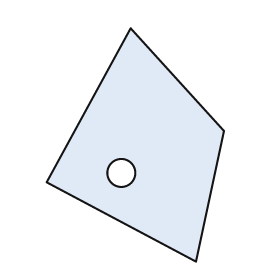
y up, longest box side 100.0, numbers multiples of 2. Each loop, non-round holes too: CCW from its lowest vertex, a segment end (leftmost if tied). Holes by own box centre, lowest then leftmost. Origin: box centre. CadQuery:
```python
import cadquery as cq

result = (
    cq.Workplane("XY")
    .moveTo(26.0, -50.0)
    .lineTo(38.0, 6.0)
    .lineTo(-2.0, 50.0)
    .lineTo(-38.0, -16.0)
    .close()
    .moveTo(-6.0, -12.0)
    .circle(6.0)
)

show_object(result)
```